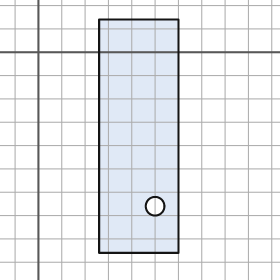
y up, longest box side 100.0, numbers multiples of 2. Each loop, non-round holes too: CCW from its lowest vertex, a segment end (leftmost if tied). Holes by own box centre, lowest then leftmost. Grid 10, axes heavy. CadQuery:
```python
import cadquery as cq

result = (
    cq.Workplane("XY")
    .moveTo(26.0, -86.0)
    .lineTo(60.0, -86.0)
    .lineTo(60.0, 14.0)
    .lineTo(26.0, 14.0)
    .close()
    .moveTo(50.0, -66.0)
    .circle(4.0)
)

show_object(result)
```